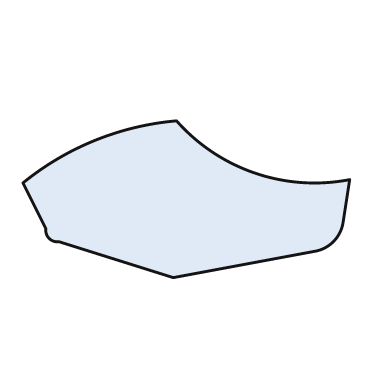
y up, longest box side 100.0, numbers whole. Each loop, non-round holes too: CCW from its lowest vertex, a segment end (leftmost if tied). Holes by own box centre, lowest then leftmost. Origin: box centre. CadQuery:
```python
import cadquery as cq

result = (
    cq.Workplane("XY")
    .moveTo(-4.0, -24.0)
    .lineTo(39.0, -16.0)
    .threePointArc((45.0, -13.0), (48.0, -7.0))
    .lineTo(50.0, 6.0)
    .threePointArc((21.0, 8.0), (-3.0, 24.0))
    .threePointArc((-28.0, 18.0), (-50.0, 5.0))
    .lineTo(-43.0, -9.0)
    .threePointArc((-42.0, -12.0), (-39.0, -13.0))
    .close()
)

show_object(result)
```